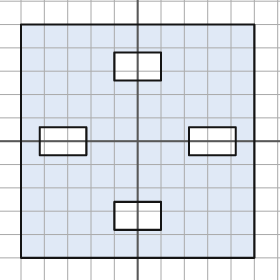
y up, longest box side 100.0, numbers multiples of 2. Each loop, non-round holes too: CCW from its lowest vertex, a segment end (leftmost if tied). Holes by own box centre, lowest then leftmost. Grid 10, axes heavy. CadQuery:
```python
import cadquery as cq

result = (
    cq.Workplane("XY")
    .moveTo(-50.0, -50.0)
    .lineTo(50.0, -50.0)
    .lineTo(50.0, 50.0)
    .lineTo(-50.0, 50.0)
    .close()
    .moveTo(-10.0, -38.0)
    .lineTo(10.0, -38.0)
    .lineTo(10.0, -26.0)
    .lineTo(-10.0, -26.0)
    .close()
    .moveTo(-42.0, -6.0)
    .lineTo(-22.0, -6.0)
    .lineTo(-22.0, 6.0)
    .lineTo(-42.0, 6.0)
    .close()
    .moveTo(22.0, -6.0)
    .lineTo(42.0, -6.0)
    .lineTo(42.0, 6.0)
    .lineTo(22.0, 6.0)
    .close()
    .moveTo(-10.0, 26.0)
    .lineTo(10.0, 26.0)
    .lineTo(10.0, 38.0)
    .lineTo(-10.0, 38.0)
    .close()
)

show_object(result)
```